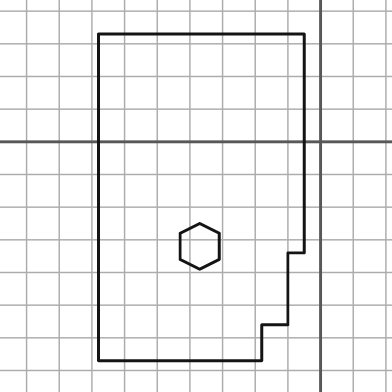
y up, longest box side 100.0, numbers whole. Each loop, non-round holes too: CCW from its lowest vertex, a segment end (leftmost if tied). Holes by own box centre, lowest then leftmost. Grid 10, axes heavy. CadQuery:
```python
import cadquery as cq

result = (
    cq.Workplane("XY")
    .moveTo(-68.0, -67.0)
    .lineTo(-18.0, -67.0)
    .lineTo(-18.0, -56.0)
    .lineTo(-10.0, -56.0)
    .lineTo(-10.0, -34.0)
    .lineTo(-5.0, -34.0)
    .lineTo(-5.0, 33.0)
    .lineTo(-68.0, 33.0)
    .close()
    .moveTo(-37.0, -39.0)
    .lineTo(-31.0, -36.0)
    .lineTo(-31.0, -28.0)
    .lineTo(-37.0, -25.0)
    .lineTo(-43.0, -28.0)
    .lineTo(-43.0, -36.0)
    .close()
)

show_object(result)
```